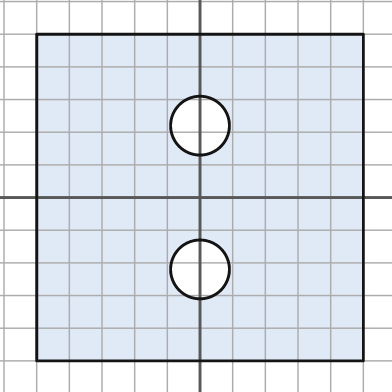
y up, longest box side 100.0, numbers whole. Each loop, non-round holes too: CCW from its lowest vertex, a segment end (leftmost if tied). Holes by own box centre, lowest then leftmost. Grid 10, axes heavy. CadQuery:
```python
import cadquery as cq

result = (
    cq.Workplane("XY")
    .moveTo(-50.0, -50.0)
    .lineTo(50.0, -50.0)
    .lineTo(50.0, 50.0)
    .lineTo(-50.0, 50.0)
    .close()
    .moveTo(0.0, -22.0)
    .circle(9.0)
    .moveTo(0.0, 22.0)
    .circle(9.0)
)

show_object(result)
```